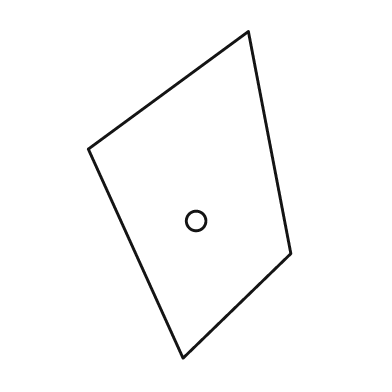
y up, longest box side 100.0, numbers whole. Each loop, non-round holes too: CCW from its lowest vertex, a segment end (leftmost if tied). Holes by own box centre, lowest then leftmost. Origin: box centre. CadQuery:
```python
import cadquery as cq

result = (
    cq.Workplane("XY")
    .moveTo(-2.0, -50.0)
    .lineTo(31.0, -18.0)
    .lineTo(18.0, 50.0)
    .lineTo(-31.0, 14.0)
    .close()
    .moveTo(2.0, -8.0)
    .circle(3.0)
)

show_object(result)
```